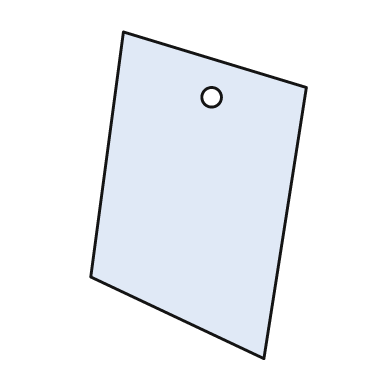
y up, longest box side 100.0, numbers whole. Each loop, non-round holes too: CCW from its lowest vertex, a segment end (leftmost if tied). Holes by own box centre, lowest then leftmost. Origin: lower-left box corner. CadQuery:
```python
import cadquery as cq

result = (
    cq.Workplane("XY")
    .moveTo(53.0, 0.0)
    .lineTo(66.0, 83.0)
    .lineTo(10.0, 100.0)
    .lineTo(0.0, 25.0)
    .close()
    .moveTo(37.0, 80.0)
    .circle(3.0)
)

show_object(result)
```